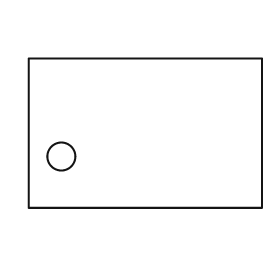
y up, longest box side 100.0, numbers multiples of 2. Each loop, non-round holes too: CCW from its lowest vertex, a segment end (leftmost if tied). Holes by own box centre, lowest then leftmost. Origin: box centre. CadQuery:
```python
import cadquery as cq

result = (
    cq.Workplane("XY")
    .moveTo(-50.0, -32.0)
    .lineTo(50.0, -32.0)
    .lineTo(50.0, 32.0)
    .lineTo(-50.0, 32.0)
    .close()
    .moveTo(-36.0, -10.0)
    .circle(6.0)
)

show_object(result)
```